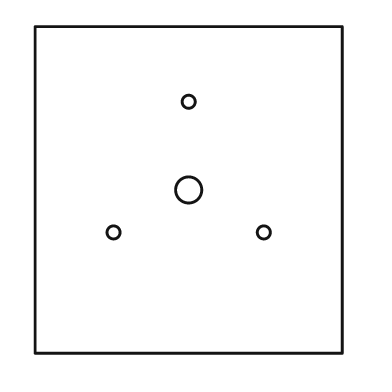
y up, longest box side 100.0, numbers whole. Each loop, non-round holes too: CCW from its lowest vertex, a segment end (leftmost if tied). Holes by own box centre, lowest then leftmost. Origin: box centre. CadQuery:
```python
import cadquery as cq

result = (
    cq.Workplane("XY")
    .moveTo(-47.0, -50.0)
    .lineTo(47.0, -50.0)
    .lineTo(47.0, 50.0)
    .lineTo(-47.0, 50.0)
    .close()
    .moveTo(-23.0, -13.0)
    .circle(2.0)
    .moveTo(23.0, -13.0)
    .circle(2.0)
    .moveTo(0.0, 0.0)
    .circle(4.0)
    .moveTo(0.0, 27.0)
    .circle(2.0)
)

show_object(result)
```